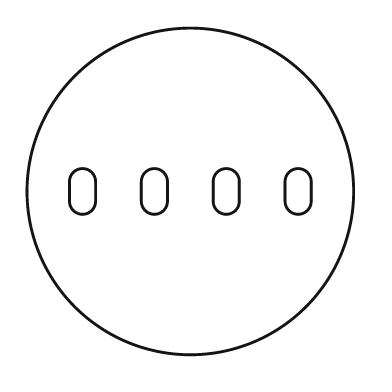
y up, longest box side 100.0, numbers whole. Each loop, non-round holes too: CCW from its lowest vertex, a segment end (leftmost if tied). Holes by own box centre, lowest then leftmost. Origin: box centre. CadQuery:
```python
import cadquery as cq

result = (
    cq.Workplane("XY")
    .moveTo(0.0, 0.0)
    .circle(50.0)
    .moveTo(-37.0, -3.0)
    .threePointArc((-33.0, -7.0), (-29.0, -3.0))
    .lineTo(-29.0, 3.0)
    .threePointArc((-33.0, 7.0), (-37.0, 3.0))
    .close()
    .moveTo(-15.0, -3.0)
    .threePointArc((-11.0, -7.0), (-7.0, -3.0))
    .lineTo(-7.0, 3.0)
    .threePointArc((-11.0, 7.0), (-15.0, 3.0))
    .close()
    .moveTo(7.0, -3.0)
    .threePointArc((11.0, -7.0), (15.0, -3.0))
    .lineTo(15.0, 3.0)
    .threePointArc((11.0, 7.0), (7.0, 3.0))
    .close()
    .moveTo(29.0, -3.0)
    .threePointArc((33.0, -7.0), (37.0, -3.0))
    .lineTo(37.0, 3.0)
    .threePointArc((33.0, 7.0), (29.0, 3.0))
    .close()
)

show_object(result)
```